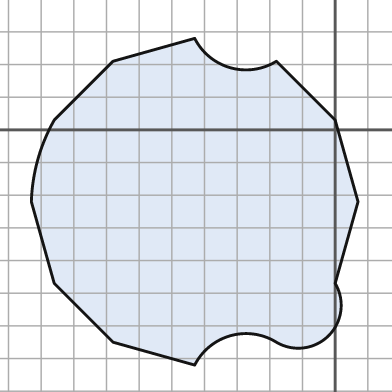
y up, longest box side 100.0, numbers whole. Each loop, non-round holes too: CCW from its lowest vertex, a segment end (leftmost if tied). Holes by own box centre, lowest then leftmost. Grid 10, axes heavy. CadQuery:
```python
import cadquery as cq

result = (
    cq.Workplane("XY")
    .moveTo(-43.0, -72.0)
    .threePointArc((-32.0, -63.0), (-18.0, -65.0))
    .threePointArc((-2.0, -63.0), (0.0, -47.0))
    .lineTo(7.0, -22.0)
    .lineTo(0.0, 3.0)
    .lineTo(-18.0, 21.0)
    .threePointArc((-32.0, 19.0), (-43.0, 28.0))
    .lineTo(-68.0, 21.0)
    .lineTo(-86.0, 3.0)
    .threePointArc((-91.0, -9.0), (-93.0, -22.0))
    .lineTo(-86.0, -47.0)
    .lineTo(-68.0, -65.0)
    .close()
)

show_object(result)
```